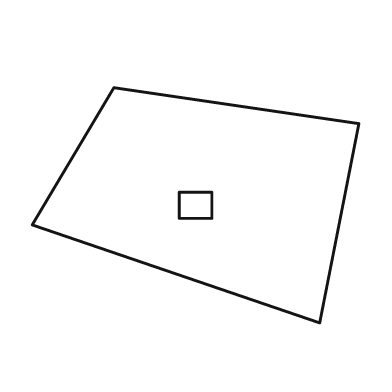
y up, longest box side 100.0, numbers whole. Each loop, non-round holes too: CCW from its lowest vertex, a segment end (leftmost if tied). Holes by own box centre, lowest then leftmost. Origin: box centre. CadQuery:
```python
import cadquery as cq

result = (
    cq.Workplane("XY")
    .moveTo(38.0, -36.0)
    .lineTo(50.0, 25.0)
    .lineTo(-25.0, 36.0)
    .lineTo(-50.0, -6.0)
    .close()
    .moveTo(-5.0, -4.0)
    .lineTo(5.0, -4.0)
    .lineTo(5.0, 4.0)
    .lineTo(-5.0, 4.0)
    .close()
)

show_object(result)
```